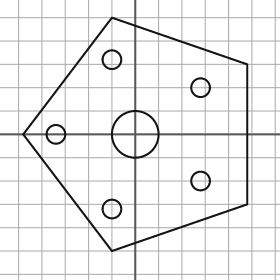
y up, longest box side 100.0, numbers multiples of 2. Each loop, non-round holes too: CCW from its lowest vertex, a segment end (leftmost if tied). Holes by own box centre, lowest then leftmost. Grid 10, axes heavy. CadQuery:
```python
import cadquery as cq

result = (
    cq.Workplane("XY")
    .moveTo(-10.0, -50.0)
    .lineTo(48.0, -30.0)
    .lineTo(48.0, 30.0)
    .lineTo(-10.0, 50.0)
    .lineTo(-48.0, 0.0)
    .close()
    .moveTo(-10.0, -32.0)
    .circle(4.0)
    .moveTo(28.0, -20.0)
    .circle(4.0)
    .moveTo(-34.0, 0.0)
    .circle(4.0)
    .moveTo(0.0, 0.0)
    .circle(10.0)
    .moveTo(28.0, 20.0)
    .circle(4.0)
    .moveTo(-10.0, 32.0)
    .circle(4.0)
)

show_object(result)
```